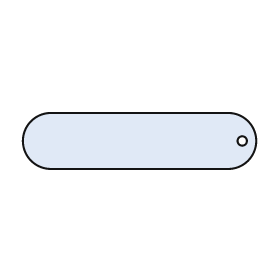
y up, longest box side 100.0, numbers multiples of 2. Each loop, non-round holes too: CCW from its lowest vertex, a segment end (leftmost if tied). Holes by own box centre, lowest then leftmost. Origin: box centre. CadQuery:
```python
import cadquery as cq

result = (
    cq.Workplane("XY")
    .moveTo(-38.0, -12.0)
    .lineTo(38.0, -12.0)
    .threePointArc((50.0, 0.0), (38.0, 12.0))
    .lineTo(-38.0, 12.0)
    .threePointArc((-50.0, 0.0), (-38.0, -12.0))
    .close()
    .moveTo(44.0, 0.0)
    .circle(2.0)
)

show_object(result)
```